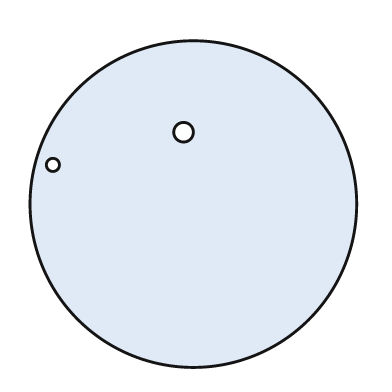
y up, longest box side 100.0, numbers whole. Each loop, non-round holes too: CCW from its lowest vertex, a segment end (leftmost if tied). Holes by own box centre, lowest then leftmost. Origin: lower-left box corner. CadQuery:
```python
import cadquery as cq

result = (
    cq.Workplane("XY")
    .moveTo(50.0, 50.0)
    .circle(50.0)
    .moveTo(7.0, 62.0)
    .circle(2.0)
    .moveTo(47.0, 72.0)
    .circle(3.0)
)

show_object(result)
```